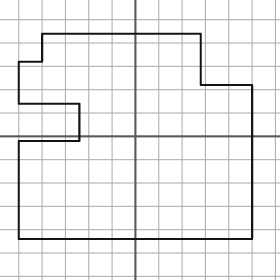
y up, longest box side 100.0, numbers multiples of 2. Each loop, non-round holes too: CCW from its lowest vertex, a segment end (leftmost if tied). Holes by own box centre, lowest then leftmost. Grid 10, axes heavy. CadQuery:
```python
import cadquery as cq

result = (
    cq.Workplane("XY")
    .moveTo(-50.0, -44.0)
    .lineTo(50.0, -44.0)
    .lineTo(50.0, 22.0)
    .lineTo(28.0, 22.0)
    .lineTo(28.0, 44.0)
    .lineTo(-40.0, 44.0)
    .lineTo(-40.0, 32.0)
    .lineTo(-50.0, 32.0)
    .lineTo(-50.0, 14.0)
    .lineTo(-24.0, 14.0)
    .lineTo(-24.0, -2.0)
    .lineTo(-50.0, -2.0)
    .close()
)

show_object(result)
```